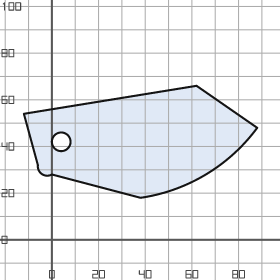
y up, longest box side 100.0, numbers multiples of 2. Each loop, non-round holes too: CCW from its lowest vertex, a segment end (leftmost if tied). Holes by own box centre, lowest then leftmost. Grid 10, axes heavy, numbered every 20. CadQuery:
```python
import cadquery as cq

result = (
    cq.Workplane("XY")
    .moveTo(38.0, 18.0)
    .threePointArc((66.0, 28.0), (88.0, 48.0))
    .lineTo(62.0, 66.0)
    .lineTo(-12.0, 54.0)
    .lineTo(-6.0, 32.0)
    .threePointArc((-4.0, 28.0), (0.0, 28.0))
    .close()
    .moveTo(4.0, 42.0)
    .circle(4.0)
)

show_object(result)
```